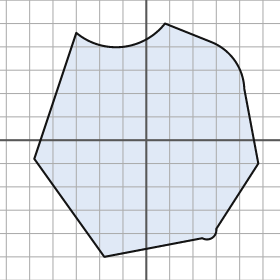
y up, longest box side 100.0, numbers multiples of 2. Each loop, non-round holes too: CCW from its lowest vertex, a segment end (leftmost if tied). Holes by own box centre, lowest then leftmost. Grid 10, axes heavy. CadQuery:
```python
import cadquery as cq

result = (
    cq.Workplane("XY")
    .moveTo(-18.0, -50.0)
    .lineTo(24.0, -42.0)
    .threePointArc((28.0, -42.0), (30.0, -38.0))
    .lineTo(48.0, -10.0)
    .lineTo(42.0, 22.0)
    .threePointArc((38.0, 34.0), (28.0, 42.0))
    .lineTo(8.0, 50.0)
    .threePointArc((-10.0, 40.0), (-30.0, 46.0))
    .lineTo(-48.0, -8.0)
    .close()
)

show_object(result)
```